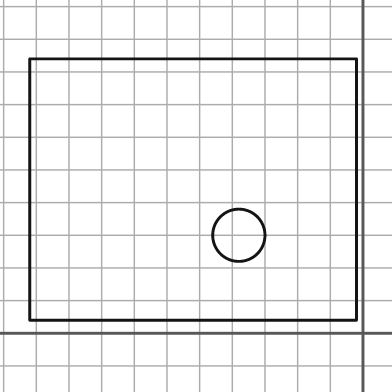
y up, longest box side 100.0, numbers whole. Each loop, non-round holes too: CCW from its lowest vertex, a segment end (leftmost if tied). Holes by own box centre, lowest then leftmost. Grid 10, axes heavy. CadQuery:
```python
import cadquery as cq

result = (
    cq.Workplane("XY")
    .moveTo(-102.0, 4.0)
    .lineTo(-2.0, 4.0)
    .lineTo(-2.0, 84.0)
    .lineTo(-102.0, 84.0)
    .close()
    .moveTo(-38.0, 30.0)
    .circle(8.0)
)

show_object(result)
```